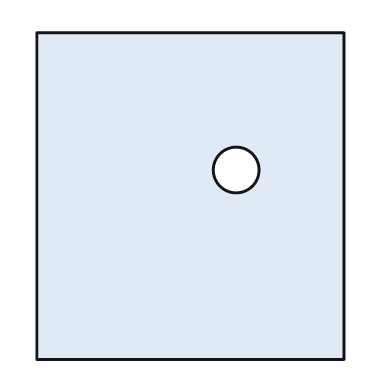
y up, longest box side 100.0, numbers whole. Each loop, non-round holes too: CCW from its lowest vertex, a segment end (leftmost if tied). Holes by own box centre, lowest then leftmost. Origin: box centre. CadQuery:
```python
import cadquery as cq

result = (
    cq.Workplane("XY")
    .moveTo(-47.0, -50.0)
    .lineTo(47.0, -50.0)
    .lineTo(47.0, 50.0)
    .lineTo(-47.0, 50.0)
    .close()
    .moveTo(14.0, 8.0)
    .circle(7.0)
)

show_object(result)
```